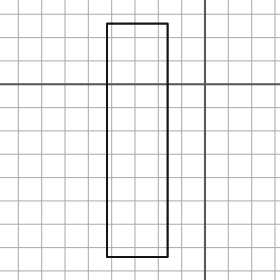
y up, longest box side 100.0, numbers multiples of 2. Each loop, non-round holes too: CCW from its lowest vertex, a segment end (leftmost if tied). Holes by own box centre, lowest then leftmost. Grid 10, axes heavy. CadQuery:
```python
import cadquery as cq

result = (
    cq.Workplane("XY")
    .moveTo(-42.0, -74.0)
    .lineTo(-16.0, -74.0)
    .lineTo(-16.0, 26.0)
    .lineTo(-42.0, 26.0)
    .close()
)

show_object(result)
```